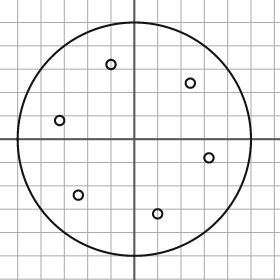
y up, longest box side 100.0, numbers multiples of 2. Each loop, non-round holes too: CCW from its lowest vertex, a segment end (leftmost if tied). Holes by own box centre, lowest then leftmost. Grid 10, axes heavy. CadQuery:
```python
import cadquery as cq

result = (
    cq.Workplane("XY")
    .moveTo(0.0, 0.0)
    .circle(50.0)
    .moveTo(10.0, -32.0)
    .circle(2.0)
    .moveTo(-24.0, -24.0)
    .circle(2.0)
    .moveTo(32.0, -8.0)
    .circle(2.0)
    .moveTo(-32.0, 8.0)
    .circle(2.0)
    .moveTo(24.0, 24.0)
    .circle(2.0)
    .moveTo(-10.0, 32.0)
    .circle(2.0)
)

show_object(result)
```